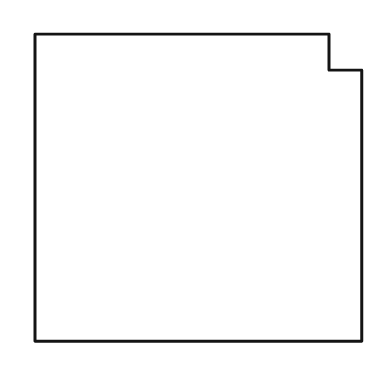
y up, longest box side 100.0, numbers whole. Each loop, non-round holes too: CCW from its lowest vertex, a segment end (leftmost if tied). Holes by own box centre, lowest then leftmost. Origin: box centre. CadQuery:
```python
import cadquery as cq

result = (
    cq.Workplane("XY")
    .moveTo(-50.0, -47.0)
    .lineTo(50.0, -47.0)
    .lineTo(50.0, 36.0)
    .lineTo(40.0, 36.0)
    .lineTo(40.0, 47.0)
    .lineTo(-50.0, 47.0)
    .close()
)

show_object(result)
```